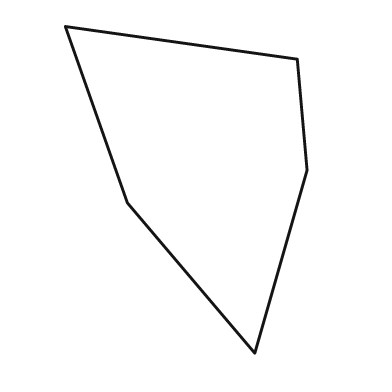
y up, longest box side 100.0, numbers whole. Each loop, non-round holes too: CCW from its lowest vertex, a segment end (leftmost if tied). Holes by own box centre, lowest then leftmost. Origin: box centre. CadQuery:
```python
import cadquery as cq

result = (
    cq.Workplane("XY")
    .moveTo(21.0, -50.0)
    .lineTo(37.0, 6.0)
    .lineTo(34.0, 40.0)
    .lineTo(-37.0, 50.0)
    .lineTo(-18.0, -4.0)
    .close()
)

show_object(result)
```